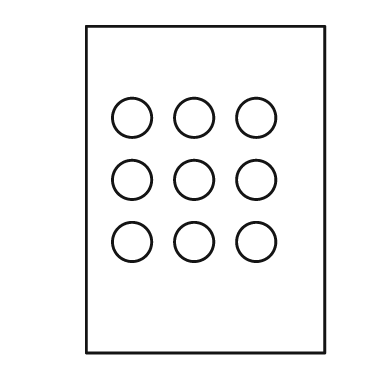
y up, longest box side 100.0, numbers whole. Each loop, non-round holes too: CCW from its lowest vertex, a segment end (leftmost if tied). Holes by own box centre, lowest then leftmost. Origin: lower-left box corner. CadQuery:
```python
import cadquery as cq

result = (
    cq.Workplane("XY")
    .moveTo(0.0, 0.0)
    .lineTo(73.0, 0.0)
    .lineTo(73.0, 100.0)
    .lineTo(0.0, 100.0)
    .close()
    .moveTo(14.0, 34.0)
    .circle(6.0)
    .moveTo(33.0, 34.0)
    .circle(6.0)
    .moveTo(52.0, 34.0)
    .circle(6.0)
    .moveTo(14.0, 53.0)
    .circle(6.0)
    .moveTo(33.0, 53.0)
    .circle(6.0)
    .moveTo(52.0, 53.0)
    .circle(6.0)
    .moveTo(14.0, 72.0)
    .circle(6.0)
    .moveTo(33.0, 72.0)
    .circle(6.0)
    .moveTo(52.0, 72.0)
    .circle(6.0)
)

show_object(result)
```